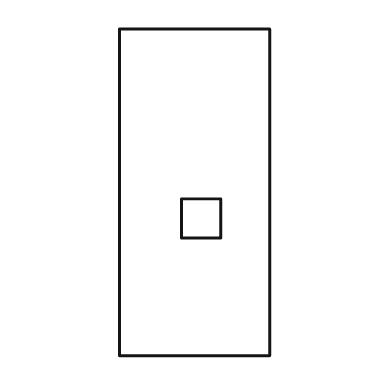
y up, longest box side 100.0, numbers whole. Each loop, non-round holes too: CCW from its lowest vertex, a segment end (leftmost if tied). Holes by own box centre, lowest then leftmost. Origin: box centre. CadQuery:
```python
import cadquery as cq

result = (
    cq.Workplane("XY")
    .moveTo(-23.0, -50.0)
    .lineTo(23.0, -50.0)
    .lineTo(23.0, 50.0)
    .lineTo(-23.0, 50.0)
    .close()
    .moveTo(-4.0, -14.0)
    .lineTo(8.0, -14.0)
    .lineTo(8.0, -2.0)
    .lineTo(-4.0, -2.0)
    .close()
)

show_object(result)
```